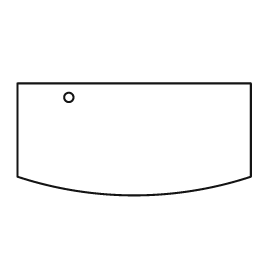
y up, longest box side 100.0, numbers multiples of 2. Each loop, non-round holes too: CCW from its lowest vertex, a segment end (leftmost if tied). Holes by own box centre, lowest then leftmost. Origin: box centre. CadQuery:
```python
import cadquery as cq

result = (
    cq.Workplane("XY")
    .moveTo(-50.0, -16.0)
    .threePointArc((0.0, -24.0), (50.0, -16.0))
    .lineTo(50.0, 24.0)
    .lineTo(-50.0, 24.0)
    .close()
    .moveTo(-28.0, 18.0)
    .circle(2.0)
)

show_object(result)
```